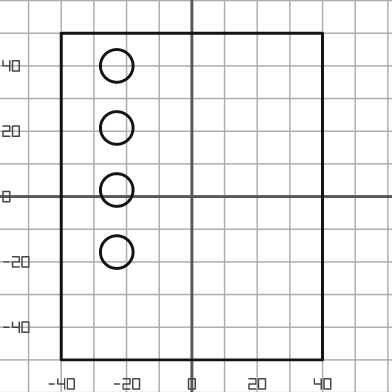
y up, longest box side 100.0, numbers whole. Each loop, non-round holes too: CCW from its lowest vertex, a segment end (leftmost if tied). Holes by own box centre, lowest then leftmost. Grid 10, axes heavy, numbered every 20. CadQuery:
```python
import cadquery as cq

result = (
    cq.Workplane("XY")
    .moveTo(-40.0, -50.0)
    .lineTo(40.0, -50.0)
    .lineTo(40.0, 50.0)
    .lineTo(-40.0, 50.0)
    .close()
    .moveTo(-23.0, -17.0)
    .circle(5.0)
    .moveTo(-23.0, 2.0)
    .circle(5.0)
    .moveTo(-23.0, 21.0)
    .circle(5.0)
    .moveTo(-23.0, 40.0)
    .circle(5.0)
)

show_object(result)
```